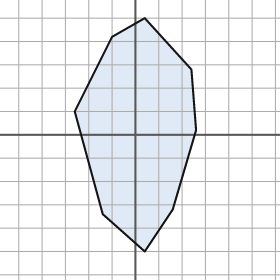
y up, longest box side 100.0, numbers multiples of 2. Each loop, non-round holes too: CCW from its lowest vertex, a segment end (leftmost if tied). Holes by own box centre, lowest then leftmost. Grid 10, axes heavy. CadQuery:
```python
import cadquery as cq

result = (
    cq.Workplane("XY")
    .moveTo(4.0, -50.0)
    .lineTo(16.0, -32.0)
    .lineTo(26.0, 2.0)
    .lineTo(24.0, 28.0)
    .lineTo(4.0, 50.0)
    .lineTo(-10.0, 42.0)
    .lineTo(-26.0, 10.0)
    .lineTo(-14.0, -34.0)
    .close()
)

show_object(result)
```